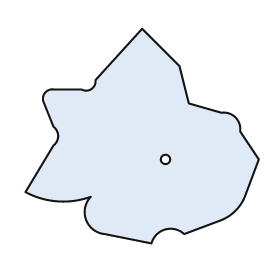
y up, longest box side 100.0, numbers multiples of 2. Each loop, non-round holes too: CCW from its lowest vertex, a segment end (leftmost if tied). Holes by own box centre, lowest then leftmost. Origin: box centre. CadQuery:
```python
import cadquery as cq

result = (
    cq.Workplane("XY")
    .moveTo(4.0, -46.0)
    .threePointArc((10.0, -40.0), (18.0, -42.0))
    .lineTo(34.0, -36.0)
    .threePointArc((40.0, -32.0), (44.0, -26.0))
    .lineTo(50.0, -10.0)
    .lineTo(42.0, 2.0)
    .threePointArc((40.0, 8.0), (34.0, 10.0))
    .lineTo(20.0, 14.0)
    .lineTo(16.0, 30.0)
    .lineTo(0.0, 46.0)
    .lineTo(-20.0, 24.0)
    .threePointArc((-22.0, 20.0), (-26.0, 20.0))
    .lineTo(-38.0, 20.0)
    .threePointArc((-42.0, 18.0), (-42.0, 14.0))
    .lineTo(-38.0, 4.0)
    .threePointArc((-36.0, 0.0), (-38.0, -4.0))
    .lineTo(-50.0, -24.0)
    .threePointArc((-36.0, -28.0), (-22.0, -26.0))
    .threePointArc((-24.0, -36.0), (-16.0, -42.0))
    .close()
    .moveTo(10.0, -10.0)
    .circle(2.0)
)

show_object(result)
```